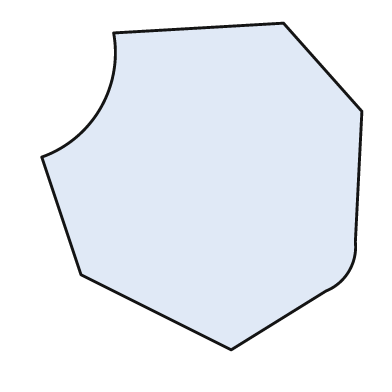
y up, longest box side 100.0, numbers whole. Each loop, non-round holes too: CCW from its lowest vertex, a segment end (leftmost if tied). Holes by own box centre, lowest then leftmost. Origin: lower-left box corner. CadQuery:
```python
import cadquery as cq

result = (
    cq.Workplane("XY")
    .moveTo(58.0, 0.0)
    .lineTo(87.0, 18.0)
    .threePointArc((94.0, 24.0), (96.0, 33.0))
    .lineTo(98.0, 73.0)
    .lineTo(74.0, 100.0)
    .lineTo(22.0, 97.0)
    .threePointArc((18.0, 74.0), (0.0, 59.0))
    .lineTo(12.0, 23.0)
    .close()
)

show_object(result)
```